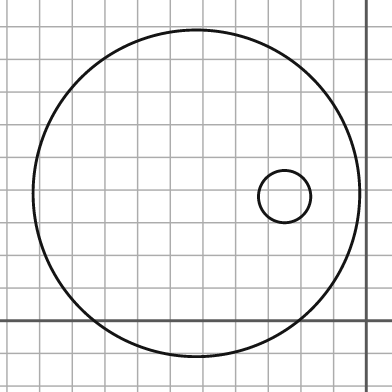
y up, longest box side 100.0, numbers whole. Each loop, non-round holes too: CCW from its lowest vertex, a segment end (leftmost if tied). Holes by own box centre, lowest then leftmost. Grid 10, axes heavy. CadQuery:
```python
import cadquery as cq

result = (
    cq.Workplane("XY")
    .moveTo(-52.0, 39.0)
    .circle(50.0)
    .moveTo(-25.0, 38.0)
    .circle(8.0)
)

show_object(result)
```